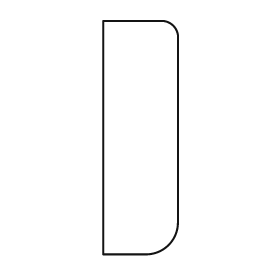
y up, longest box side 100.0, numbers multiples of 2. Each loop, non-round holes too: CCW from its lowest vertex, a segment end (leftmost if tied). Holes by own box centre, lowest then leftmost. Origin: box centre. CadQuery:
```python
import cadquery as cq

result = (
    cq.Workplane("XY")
    .moveTo(-16.0, -50.0)
    .lineTo(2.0, -50.0)
    .threePointArc((12.0, -46.0), (16.0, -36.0))
    .lineTo(16.0, 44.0)
    .threePointArc((14.0, 48.0), (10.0, 50.0))
    .lineTo(-16.0, 50.0)
    .close()
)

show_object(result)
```